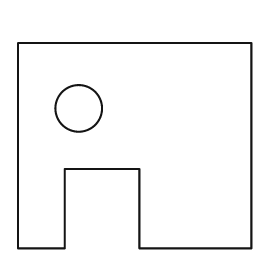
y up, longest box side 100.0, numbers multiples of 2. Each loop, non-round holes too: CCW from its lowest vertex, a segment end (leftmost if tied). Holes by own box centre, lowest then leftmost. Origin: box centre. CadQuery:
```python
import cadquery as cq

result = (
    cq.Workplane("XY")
    .moveTo(-50.0, -44.0)
    .lineTo(-30.0, -44.0)
    .lineTo(-30.0, -10.0)
    .lineTo(2.0, -10.0)
    .lineTo(2.0, -44.0)
    .lineTo(50.0, -44.0)
    .lineTo(50.0, 44.0)
    .lineTo(-50.0, 44.0)
    .close()
    .moveTo(-24.0, 16.0)
    .circle(10.0)
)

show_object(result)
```